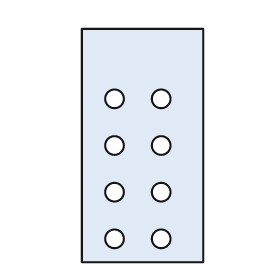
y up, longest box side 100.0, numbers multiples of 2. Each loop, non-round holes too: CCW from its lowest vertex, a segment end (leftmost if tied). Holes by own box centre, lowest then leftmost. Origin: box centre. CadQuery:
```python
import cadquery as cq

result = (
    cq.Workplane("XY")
    .moveTo(-26.0, -50.0)
    .lineTo(26.0, -50.0)
    .lineTo(26.0, 50.0)
    .lineTo(-26.0, 50.0)
    .close()
    .moveTo(-12.0, -40.0)
    .circle(4.0)
    .moveTo(8.0, -40.0)
    .circle(4.0)
    .moveTo(-12.0, -20.0)
    .circle(4.0)
    .moveTo(8.0, -20.0)
    .circle(4.0)
    .moveTo(-12.0, 0.0)
    .circle(4.0)
    .moveTo(8.0, 0.0)
    .circle(4.0)
    .moveTo(-12.0, 20.0)
    .circle(4.0)
    .moveTo(8.0, 20.0)
    .circle(4.0)
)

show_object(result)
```